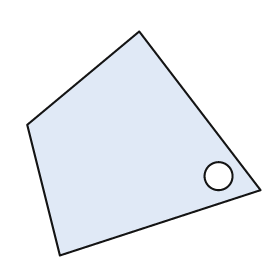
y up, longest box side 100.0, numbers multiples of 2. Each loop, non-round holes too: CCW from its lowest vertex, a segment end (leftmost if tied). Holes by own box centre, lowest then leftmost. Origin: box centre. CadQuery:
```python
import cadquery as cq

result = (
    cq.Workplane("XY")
    .moveTo(-36.0, -48.0)
    .lineTo(50.0, -20.0)
    .lineTo(-2.0, 48.0)
    .lineTo(-50.0, 8.0)
    .close()
    .moveTo(32.0, -14.0)
    .circle(6.0)
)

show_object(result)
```